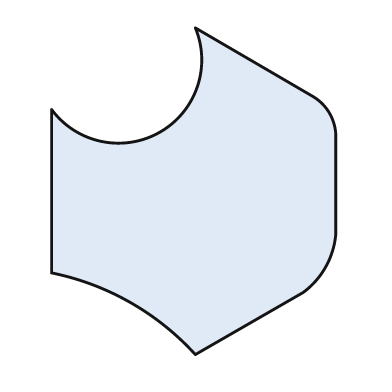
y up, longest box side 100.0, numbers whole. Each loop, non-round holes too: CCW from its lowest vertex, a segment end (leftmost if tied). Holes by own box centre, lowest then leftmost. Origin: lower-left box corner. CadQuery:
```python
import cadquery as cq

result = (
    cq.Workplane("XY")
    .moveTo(44.0, 0.0)
    .lineTo(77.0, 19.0)
    .threePointArc((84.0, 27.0), (87.0, 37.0))
    .lineTo(87.0, 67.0)
    .threePointArc((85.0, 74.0), (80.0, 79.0))
    .lineTo(44.0, 100.0)
    .threePointArc((33.0, 68.0), (0.0, 75.0))
    .lineTo(0.0, 25.0)
    .threePointArc((24.0, 16.0), (44.0, 0.0))
    .close()
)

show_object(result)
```